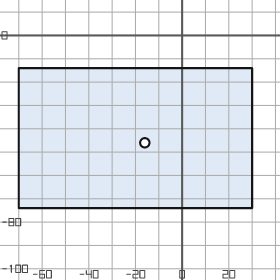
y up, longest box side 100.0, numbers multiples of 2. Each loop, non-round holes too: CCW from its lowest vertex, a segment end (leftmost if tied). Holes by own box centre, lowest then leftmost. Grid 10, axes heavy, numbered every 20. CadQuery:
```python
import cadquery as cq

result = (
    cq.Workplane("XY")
    .moveTo(-70.0, -74.0)
    .lineTo(30.0, -74.0)
    .lineTo(30.0, -14.0)
    .lineTo(-70.0, -14.0)
    .close()
    .moveTo(-16.0, -46.0)
    .circle(2.0)
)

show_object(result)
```